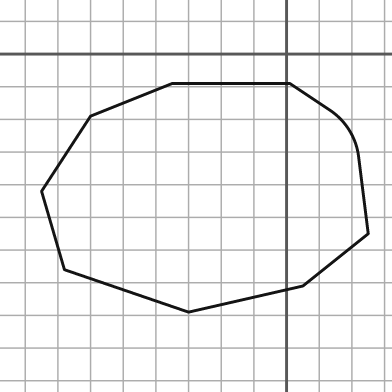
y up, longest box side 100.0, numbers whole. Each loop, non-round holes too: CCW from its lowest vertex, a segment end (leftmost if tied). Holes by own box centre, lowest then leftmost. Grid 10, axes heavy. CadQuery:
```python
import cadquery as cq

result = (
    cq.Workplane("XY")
    .moveTo(-30.0, -79.0)
    .lineTo(5.0, -71.0)
    .lineTo(25.0, -55.0)
    .lineTo(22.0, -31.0)
    .threePointArc((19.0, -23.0), (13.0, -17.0))
    .lineTo(1.0, -9.0)
    .lineTo(-35.0, -9.0)
    .lineTo(-60.0, -19.0)
    .lineTo(-75.0, -42.0)
    .lineTo(-68.0, -66.0)
    .close()
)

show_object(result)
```